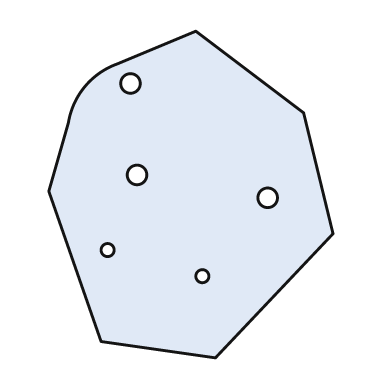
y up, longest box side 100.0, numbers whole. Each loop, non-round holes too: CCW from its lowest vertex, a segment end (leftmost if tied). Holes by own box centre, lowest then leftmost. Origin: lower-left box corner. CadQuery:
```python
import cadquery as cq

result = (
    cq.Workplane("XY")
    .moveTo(51.0, 0.0)
    .lineTo(87.0, 38.0)
    .lineTo(78.0, 75.0)
    .lineTo(45.0, 100.0)
    .lineTo(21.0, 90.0)
    .threePointArc((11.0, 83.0), (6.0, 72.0))
    .lineTo(0.0, 51.0)
    .lineTo(16.0, 5.0)
    .close()
    .moveTo(47.0, 25.0)
    .circle(2.0)
    .moveTo(18.0, 33.0)
    .circle(2.0)
    .moveTo(67.0, 49.0)
    .circle(3.0)
    .moveTo(27.0, 56.0)
    .circle(3.0)
    .moveTo(25.0, 84.0)
    .circle(3.0)
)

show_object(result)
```